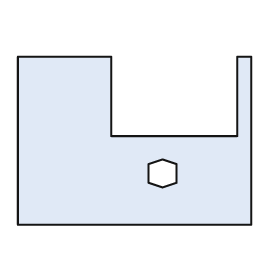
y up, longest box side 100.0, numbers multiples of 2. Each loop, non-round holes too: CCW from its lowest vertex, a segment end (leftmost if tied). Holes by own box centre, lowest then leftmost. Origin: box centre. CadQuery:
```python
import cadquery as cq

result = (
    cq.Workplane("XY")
    .moveTo(-50.0, -36.0)
    .lineTo(50.0, -36.0)
    .lineTo(50.0, 36.0)
    .lineTo(44.0, 36.0)
    .lineTo(44.0, 2.0)
    .lineTo(-10.0, 2.0)
    .lineTo(-10.0, 36.0)
    .lineTo(-50.0, 36.0)
    .close()
    .moveTo(12.0, -20.0)
    .lineTo(18.0, -18.0)
    .lineTo(18.0, -10.0)
    .lineTo(12.0, -8.0)
    .lineTo(6.0, -10.0)
    .lineTo(6.0, -18.0)
    .close()
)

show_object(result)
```